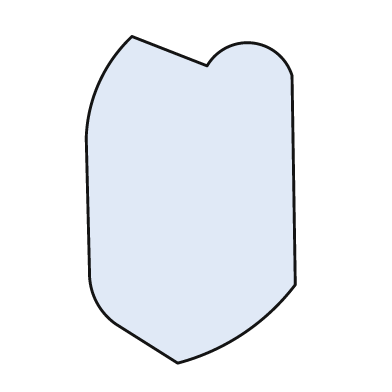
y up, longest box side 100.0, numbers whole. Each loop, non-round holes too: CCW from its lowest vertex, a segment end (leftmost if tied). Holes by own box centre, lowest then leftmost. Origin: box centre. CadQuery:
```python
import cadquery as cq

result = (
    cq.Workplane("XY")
    .moveTo(-4.0, -50.0)
    .threePointArc((16.0, -41.0), (32.0, -26.0))
    .lineTo(31.0, 38.0)
    .threePointArc((19.0, 48.0), (5.0, 41.0))
    .lineTo(-18.0, 50.0)
    .threePointArc((-28.0, 36.0), (-32.0, 19.0))
    .lineTo(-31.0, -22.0)
    .threePointArc((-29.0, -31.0), (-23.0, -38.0))
    .close()
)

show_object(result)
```